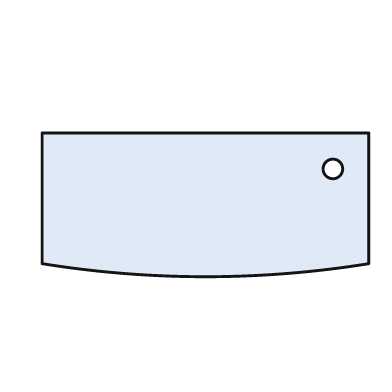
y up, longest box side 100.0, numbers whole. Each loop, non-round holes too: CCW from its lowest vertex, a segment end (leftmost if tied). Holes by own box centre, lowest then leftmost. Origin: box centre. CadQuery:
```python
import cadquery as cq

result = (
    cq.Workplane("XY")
    .moveTo(-50.0, -18.0)
    .threePointArc((0.0, -22.0), (50.0, -18.0))
    .lineTo(50.0, 22.0)
    .lineTo(-50.0, 22.0)
    .close()
    .moveTo(39.0, 11.0)
    .circle(3.0)
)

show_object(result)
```